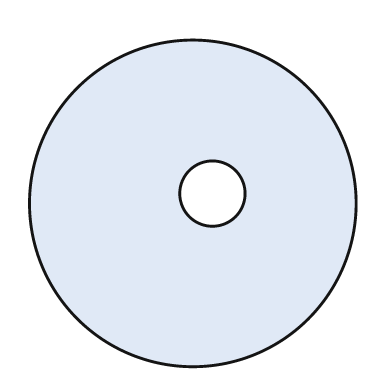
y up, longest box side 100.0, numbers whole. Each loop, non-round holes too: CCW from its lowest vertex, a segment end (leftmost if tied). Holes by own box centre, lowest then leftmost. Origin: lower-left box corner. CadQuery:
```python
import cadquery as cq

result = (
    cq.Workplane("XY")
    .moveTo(50.0, 50.0)
    .circle(50.0)
    .moveTo(56.0, 53.0)
    .circle(10.0)
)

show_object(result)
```